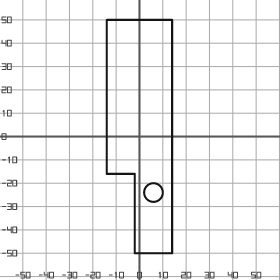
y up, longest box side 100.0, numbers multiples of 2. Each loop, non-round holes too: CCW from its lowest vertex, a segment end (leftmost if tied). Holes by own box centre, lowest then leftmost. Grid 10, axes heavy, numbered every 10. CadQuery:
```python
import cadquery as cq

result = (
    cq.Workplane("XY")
    .moveTo(-2.0, -50.0)
    .lineTo(14.0, -50.0)
    .lineTo(14.0, 50.0)
    .lineTo(-14.0, 50.0)
    .lineTo(-14.0, -16.0)
    .lineTo(-2.0, -16.0)
    .close()
    .moveTo(6.0, -24.0)
    .circle(4.0)
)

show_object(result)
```